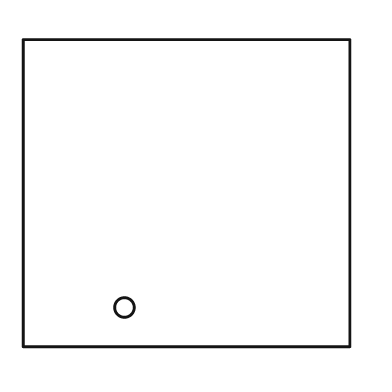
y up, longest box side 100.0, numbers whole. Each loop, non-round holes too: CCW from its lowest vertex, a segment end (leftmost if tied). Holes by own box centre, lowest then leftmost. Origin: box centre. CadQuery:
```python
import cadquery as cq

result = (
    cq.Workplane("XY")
    .moveTo(-50.0, -47.0)
    .lineTo(50.0, -47.0)
    .lineTo(50.0, 47.0)
    .lineTo(-50.0, 47.0)
    .close()
    .moveTo(-19.0, -35.0)
    .circle(3.0)
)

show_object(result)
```